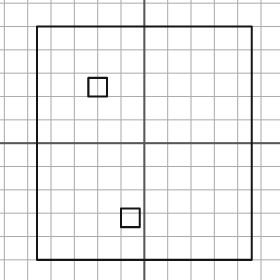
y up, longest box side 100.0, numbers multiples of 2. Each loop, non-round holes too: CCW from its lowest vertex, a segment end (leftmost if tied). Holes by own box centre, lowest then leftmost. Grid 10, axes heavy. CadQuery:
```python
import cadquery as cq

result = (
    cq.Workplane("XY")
    .moveTo(-46.0, -50.0)
    .lineTo(46.0, -50.0)
    .lineTo(46.0, 50.0)
    .lineTo(-46.0, 50.0)
    .close()
    .moveTo(-10.0, -36.0)
    .lineTo(-2.0, -36.0)
    .lineTo(-2.0, -28.0)
    .lineTo(-10.0, -28.0)
    .close()
    .moveTo(-24.0, 20.0)
    .lineTo(-16.0, 20.0)
    .lineTo(-16.0, 28.0)
    .lineTo(-24.0, 28.0)
    .close()
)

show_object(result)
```